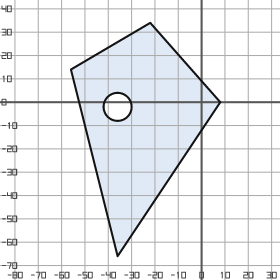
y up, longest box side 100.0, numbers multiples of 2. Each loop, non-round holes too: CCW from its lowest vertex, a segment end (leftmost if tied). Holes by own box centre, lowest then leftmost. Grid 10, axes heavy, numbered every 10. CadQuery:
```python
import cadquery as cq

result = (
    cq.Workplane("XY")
    .moveTo(-36.0, -66.0)
    .lineTo(8.0, 0.0)
    .lineTo(-22.0, 34.0)
    .lineTo(-56.0, 14.0)
    .close()
    .moveTo(-36.0, -2.0)
    .circle(6.0)
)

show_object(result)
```